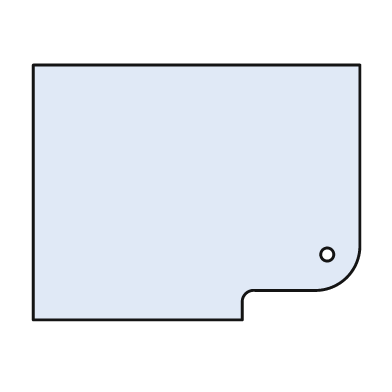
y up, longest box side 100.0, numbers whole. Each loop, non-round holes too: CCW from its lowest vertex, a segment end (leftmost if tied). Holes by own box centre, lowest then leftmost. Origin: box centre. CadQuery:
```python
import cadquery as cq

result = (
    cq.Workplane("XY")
    .moveTo(-50.0, -39.0)
    .lineTo(14.0, -39.0)
    .lineTo(14.0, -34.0)
    .threePointArc((15.0, -31.0), (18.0, -30.0))
    .lineTo(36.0, -30.0)
    .threePointArc((46.0, -26.0), (50.0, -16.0))
    .lineTo(50.0, 39.0)
    .lineTo(-50.0, 39.0)
    .close()
    .moveTo(40.0, -19.0)
    .circle(2.0)
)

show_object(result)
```